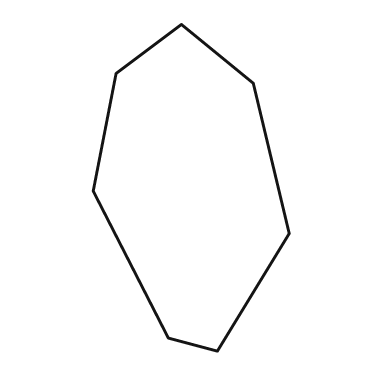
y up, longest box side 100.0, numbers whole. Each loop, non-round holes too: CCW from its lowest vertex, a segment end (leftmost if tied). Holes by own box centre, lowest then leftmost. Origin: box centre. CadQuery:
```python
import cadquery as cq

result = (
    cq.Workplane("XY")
    .moveTo(8.0, -50.0)
    .lineTo(30.0, -14.0)
    .lineTo(19.0, 32.0)
    .lineTo(-3.0, 50.0)
    .lineTo(-23.0, 35.0)
    .lineTo(-30.0, -1.0)
    .lineTo(-7.0, -46.0)
    .close()
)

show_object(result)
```